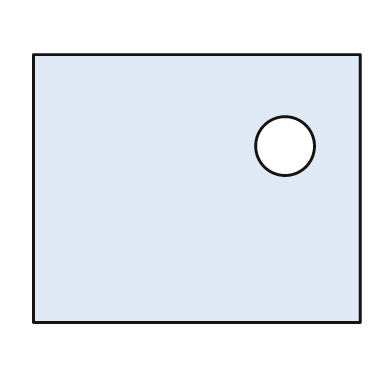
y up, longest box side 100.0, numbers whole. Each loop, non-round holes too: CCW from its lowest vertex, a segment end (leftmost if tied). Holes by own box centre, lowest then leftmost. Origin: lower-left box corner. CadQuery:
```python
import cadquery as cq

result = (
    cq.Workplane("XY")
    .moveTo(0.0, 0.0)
    .lineTo(100.0, 0.0)
    .lineTo(100.0, 82.0)
    .lineTo(0.0, 82.0)
    .close()
    .moveTo(77.0, 54.0)
    .circle(9.0)
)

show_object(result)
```